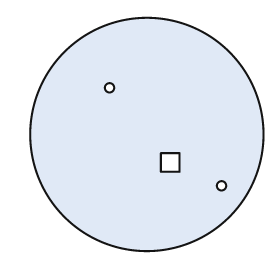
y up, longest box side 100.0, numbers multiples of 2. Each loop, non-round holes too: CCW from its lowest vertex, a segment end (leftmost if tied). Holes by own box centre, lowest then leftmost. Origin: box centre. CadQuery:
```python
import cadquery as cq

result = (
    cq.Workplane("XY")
    .moveTo(0.0, 0.0)
    .circle(50.0)
    .moveTo(32.0, -22.0)
    .circle(2.0)
    .moveTo(6.0, -16.0)
    .lineTo(14.0, -16.0)
    .lineTo(14.0, -8.0)
    .lineTo(6.0, -8.0)
    .close()
    .moveTo(-16.0, 20.0)
    .circle(2.0)
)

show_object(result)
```